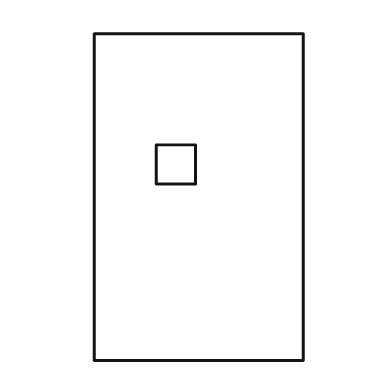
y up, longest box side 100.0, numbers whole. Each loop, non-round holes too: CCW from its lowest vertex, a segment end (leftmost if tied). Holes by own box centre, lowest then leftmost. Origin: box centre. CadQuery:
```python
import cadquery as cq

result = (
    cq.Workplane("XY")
    .moveTo(-32.0, -50.0)
    .lineTo(32.0, -50.0)
    .lineTo(32.0, 50.0)
    .lineTo(-32.0, 50.0)
    .close()
    .moveTo(-13.0, 4.0)
    .lineTo(-1.0, 4.0)
    .lineTo(-1.0, 16.0)
    .lineTo(-13.0, 16.0)
    .close()
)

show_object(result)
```